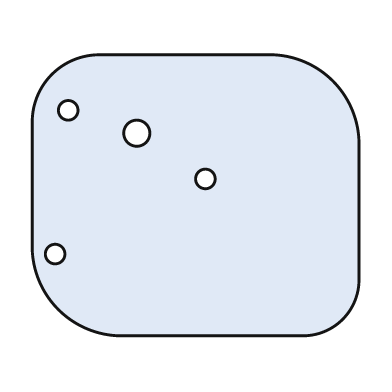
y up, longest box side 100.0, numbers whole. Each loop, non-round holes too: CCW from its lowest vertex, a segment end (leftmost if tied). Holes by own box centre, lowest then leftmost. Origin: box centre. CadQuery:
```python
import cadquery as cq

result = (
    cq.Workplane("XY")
    .moveTo(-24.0, -43.0)
    .lineTo(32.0, -43.0)
    .threePointArc((45.0, -38.0), (50.0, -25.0))
    .lineTo(50.0, 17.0)
    .threePointArc((42.0, 35.0), (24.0, 43.0))
    .lineTo(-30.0, 43.0)
    .threePointArc((-44.0, 37.0), (-50.0, 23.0))
    .lineTo(-50.0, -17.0)
    .threePointArc((-42.0, -35.0), (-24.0, -43.0))
    .close()
    .moveTo(-43.0, -18.0)
    .circle(3.0)
    .moveTo(3.0, 5.0)
    .circle(3.0)
    .moveTo(-18.0, 19.0)
    .circle(4.0)
    .moveTo(-39.0, 26.0)
    .circle(3.0)
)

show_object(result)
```